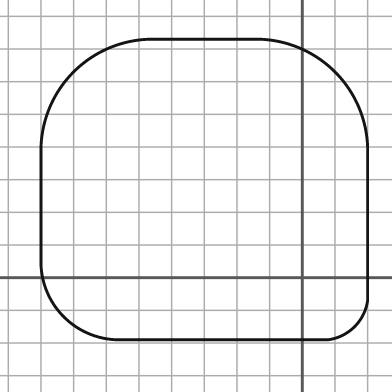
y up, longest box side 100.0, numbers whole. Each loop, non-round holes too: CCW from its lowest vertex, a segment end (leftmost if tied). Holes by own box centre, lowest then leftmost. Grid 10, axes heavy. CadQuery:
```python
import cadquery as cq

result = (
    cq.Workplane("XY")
    .moveTo(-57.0, -19.0)
    .lineTo(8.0, -19.0)
    .threePointArc((16.0, -15.0), (20.0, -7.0))
    .lineTo(20.0, 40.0)
    .threePointArc((10.0, 63.0), (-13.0, 73.0))
    .lineTo(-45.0, 73.0)
    .threePointArc((-70.0, 63.0), (-80.0, 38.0))
    .lineTo(-80.0, 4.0)
    .threePointArc((-73.0, -12.0), (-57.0, -19.0))
    .close()
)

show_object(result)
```